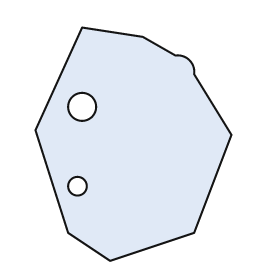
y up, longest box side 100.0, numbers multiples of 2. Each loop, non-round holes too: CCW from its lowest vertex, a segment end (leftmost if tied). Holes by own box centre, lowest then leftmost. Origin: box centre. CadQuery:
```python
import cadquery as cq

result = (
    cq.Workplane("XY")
    .moveTo(-10.0, -50.0)
    .lineTo(26.0, -38.0)
    .lineTo(42.0, 4.0)
    .lineTo(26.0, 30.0)
    .threePointArc((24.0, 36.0), (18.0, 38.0))
    .lineTo(4.0, 46.0)
    .lineTo(-22.0, 50.0)
    .lineTo(-42.0, 6.0)
    .lineTo(-28.0, -38.0)
    .close()
    .moveTo(-24.0, -18.0)
    .circle(4.0)
    .moveTo(-22.0, 16.0)
    .circle(6.0)
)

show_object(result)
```